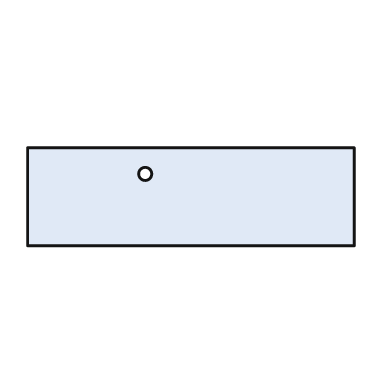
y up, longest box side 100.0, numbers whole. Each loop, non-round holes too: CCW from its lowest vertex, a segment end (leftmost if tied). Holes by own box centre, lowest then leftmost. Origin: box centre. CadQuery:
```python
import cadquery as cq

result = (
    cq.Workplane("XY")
    .moveTo(-50.0, -15.0)
    .lineTo(50.0, -15.0)
    .lineTo(50.0, 15.0)
    .lineTo(-50.0, 15.0)
    .close()
    .moveTo(-14.0, 7.0)
    .circle(2.0)
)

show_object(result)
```